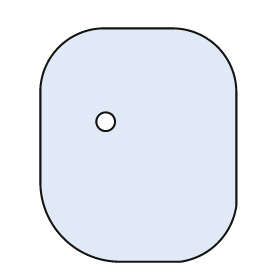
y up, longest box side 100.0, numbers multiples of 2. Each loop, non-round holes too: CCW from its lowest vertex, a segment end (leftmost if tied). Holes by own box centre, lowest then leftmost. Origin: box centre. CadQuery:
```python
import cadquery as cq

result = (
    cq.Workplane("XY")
    .moveTo(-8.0, -50.0)
    .lineTo(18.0, -50.0)
    .threePointArc((34.0, -42.0), (42.0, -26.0))
    .lineTo(42.0, 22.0)
    .threePointArc((34.0, 42.0), (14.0, 50.0))
    .lineTo(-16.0, 50.0)
    .threePointArc((-34.0, 42.0), (-42.0, 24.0))
    .lineTo(-42.0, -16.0)
    .threePointArc((-32.0, -40.0), (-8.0, -50.0))
    .close()
    .moveTo(-14.0, 10.0)
    .circle(4.0)
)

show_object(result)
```